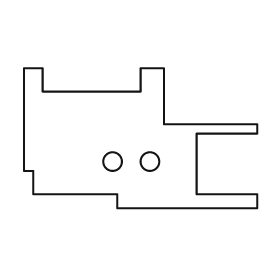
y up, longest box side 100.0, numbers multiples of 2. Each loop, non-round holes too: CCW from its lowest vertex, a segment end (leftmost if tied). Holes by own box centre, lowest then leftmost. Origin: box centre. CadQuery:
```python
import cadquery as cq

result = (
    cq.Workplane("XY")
    .moveTo(-10.0, -30.0)
    .lineTo(50.0, -30.0)
    .lineTo(50.0, -24.0)
    .lineTo(24.0, -24.0)
    .lineTo(24.0, 2.0)
    .lineTo(50.0, 2.0)
    .lineTo(50.0, 6.0)
    .lineTo(10.0, 6.0)
    .lineTo(10.0, 30.0)
    .lineTo(0.0, 30.0)
    .lineTo(0.0, 20.0)
    .lineTo(-42.0, 20.0)
    .lineTo(-42.0, 30.0)
    .lineTo(-50.0, 30.0)
    .lineTo(-50.0, -14.0)
    .lineTo(-46.0, -14.0)
    .lineTo(-46.0, -24.0)
    .lineTo(-10.0, -24.0)
    .close()
    .moveTo(-12.0, -10.0)
    .circle(4.0)
    .moveTo(4.0, -10.0)
    .circle(4.0)
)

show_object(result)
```